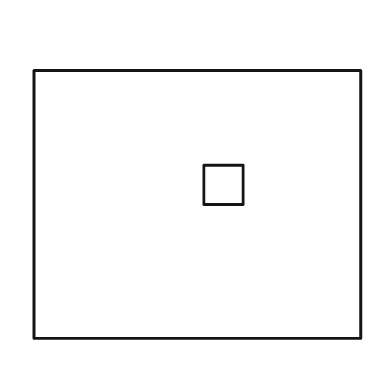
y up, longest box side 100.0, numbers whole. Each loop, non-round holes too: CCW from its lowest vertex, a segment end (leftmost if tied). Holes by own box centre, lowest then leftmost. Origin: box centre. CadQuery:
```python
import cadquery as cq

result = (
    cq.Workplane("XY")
    .moveTo(-50.0, -41.0)
    .lineTo(50.0, -41.0)
    .lineTo(50.0, 41.0)
    .lineTo(-50.0, 41.0)
    .close()
    .moveTo(2.0, 0.0)
    .lineTo(14.0, 0.0)
    .lineTo(14.0, 12.0)
    .lineTo(2.0, 12.0)
    .close()
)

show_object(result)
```